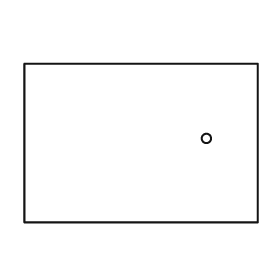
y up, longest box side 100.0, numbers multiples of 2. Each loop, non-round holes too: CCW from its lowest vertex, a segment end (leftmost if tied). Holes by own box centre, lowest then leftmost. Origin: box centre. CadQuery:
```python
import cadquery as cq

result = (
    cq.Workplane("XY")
    .moveTo(-50.0, -34.0)
    .lineTo(50.0, -34.0)
    .lineTo(50.0, 34.0)
    .lineTo(-50.0, 34.0)
    .close()
    .moveTo(28.0, 2.0)
    .circle(2.0)
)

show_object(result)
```